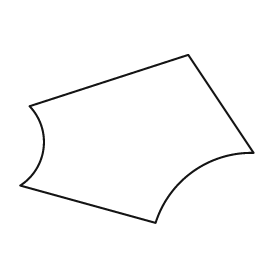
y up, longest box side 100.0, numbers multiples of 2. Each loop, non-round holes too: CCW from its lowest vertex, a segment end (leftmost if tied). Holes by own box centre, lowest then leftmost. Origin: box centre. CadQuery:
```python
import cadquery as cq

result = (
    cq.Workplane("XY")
    .moveTo(8.0, -36.0)
    .threePointArc((24.0, -14.0), (50.0, -6.0))
    .lineTo(22.0, 36.0)
    .lineTo(-46.0, 14.0)
    .threePointArc((-40.0, -4.0), (-50.0, -20.0))
    .close()
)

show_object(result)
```